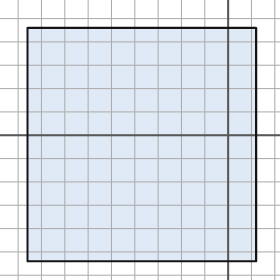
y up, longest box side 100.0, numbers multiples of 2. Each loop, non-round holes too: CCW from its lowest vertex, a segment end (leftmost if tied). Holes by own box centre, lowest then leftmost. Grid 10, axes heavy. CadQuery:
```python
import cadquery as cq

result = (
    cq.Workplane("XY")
    .moveTo(-86.0, -54.0)
    .lineTo(12.0, -54.0)
    .lineTo(12.0, 46.0)
    .lineTo(-86.0, 46.0)
    .close()
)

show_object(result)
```